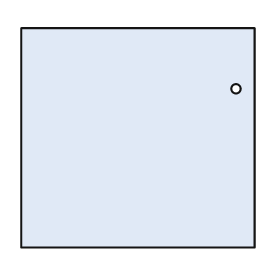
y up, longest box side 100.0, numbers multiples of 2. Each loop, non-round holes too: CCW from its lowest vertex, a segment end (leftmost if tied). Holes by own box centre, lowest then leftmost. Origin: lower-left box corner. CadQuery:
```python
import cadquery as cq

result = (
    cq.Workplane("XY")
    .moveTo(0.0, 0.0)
    .lineTo(100.0, 0.0)
    .lineTo(100.0, 94.0)
    .lineTo(0.0, 94.0)
    .close()
    .moveTo(92.0, 68.0)
    .circle(2.0)
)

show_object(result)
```